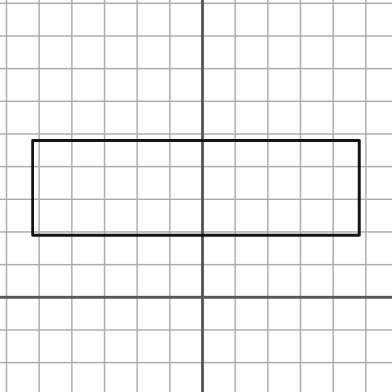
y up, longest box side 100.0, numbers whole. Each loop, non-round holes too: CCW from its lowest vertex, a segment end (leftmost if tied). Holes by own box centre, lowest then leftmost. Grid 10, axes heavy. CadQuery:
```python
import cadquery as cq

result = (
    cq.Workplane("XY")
    .moveTo(-52.0, 19.0)
    .lineTo(48.0, 19.0)
    .lineTo(48.0, 48.0)
    .lineTo(-52.0, 48.0)
    .close()
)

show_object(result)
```